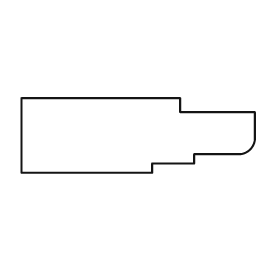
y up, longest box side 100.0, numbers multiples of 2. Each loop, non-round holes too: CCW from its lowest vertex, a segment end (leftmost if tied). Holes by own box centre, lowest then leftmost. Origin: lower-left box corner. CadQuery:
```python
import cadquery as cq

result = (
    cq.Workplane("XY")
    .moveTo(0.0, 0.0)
    .lineTo(56.0, 0.0)
    .lineTo(56.0, 4.0)
    .lineTo(74.0, 4.0)
    .lineTo(74.0, 8.0)
    .lineTo(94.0, 8.0)
    .threePointArc((98.0, 10.0), (100.0, 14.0))
    .lineTo(100.0, 26.0)
    .lineTo(68.0, 26.0)
    .lineTo(68.0, 32.0)
    .lineTo(0.0, 32.0)
    .close()
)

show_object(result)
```